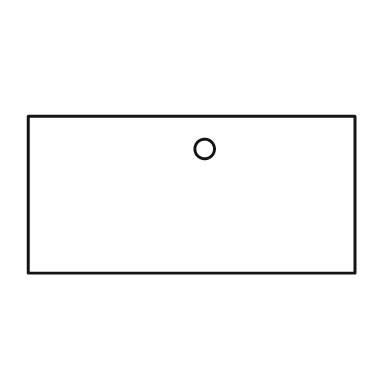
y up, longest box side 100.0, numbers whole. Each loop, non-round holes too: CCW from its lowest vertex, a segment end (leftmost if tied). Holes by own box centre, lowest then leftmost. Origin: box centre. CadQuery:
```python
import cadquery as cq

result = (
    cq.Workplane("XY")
    .moveTo(-50.0, -24.0)
    .lineTo(50.0, -24.0)
    .lineTo(50.0, 24.0)
    .lineTo(-50.0, 24.0)
    .close()
    .moveTo(4.0, 14.0)
    .circle(3.0)
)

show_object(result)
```